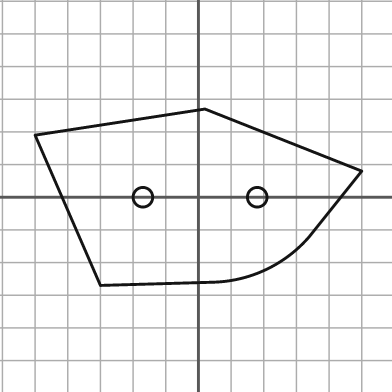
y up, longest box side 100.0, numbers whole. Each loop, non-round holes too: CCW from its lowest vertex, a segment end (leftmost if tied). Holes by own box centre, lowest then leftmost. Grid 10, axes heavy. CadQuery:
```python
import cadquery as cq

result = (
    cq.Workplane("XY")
    .moveTo(-30.0, -27.0)
    .lineTo(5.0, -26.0)
    .threePointArc((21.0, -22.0), (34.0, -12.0))
    .lineTo(50.0, 8.0)
    .lineTo(2.0, 27.0)
    .lineTo(-50.0, 19.0)
    .close()
    .moveTo(-17.0, 0.0)
    .circle(3.0)
    .moveTo(18.0, 0.0)
    .circle(3.0)
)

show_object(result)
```